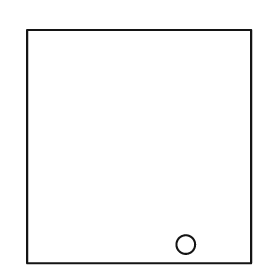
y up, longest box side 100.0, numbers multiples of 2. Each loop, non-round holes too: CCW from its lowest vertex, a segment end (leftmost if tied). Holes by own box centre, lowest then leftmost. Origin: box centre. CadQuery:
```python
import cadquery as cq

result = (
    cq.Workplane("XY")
    .moveTo(-48.0, -50.0)
    .lineTo(48.0, -50.0)
    .lineTo(48.0, 50.0)
    .lineTo(-48.0, 50.0)
    .close()
    .moveTo(20.0, -42.0)
    .circle(4.0)
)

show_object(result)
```